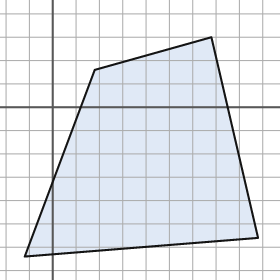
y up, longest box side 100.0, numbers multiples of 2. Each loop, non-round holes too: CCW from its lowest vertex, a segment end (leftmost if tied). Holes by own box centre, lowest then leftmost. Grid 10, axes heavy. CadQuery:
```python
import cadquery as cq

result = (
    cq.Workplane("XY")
    .moveTo(-12.0, -64.0)
    .lineTo(88.0, -56.0)
    .lineTo(68.0, 30.0)
    .lineTo(18.0, 16.0)
    .close()
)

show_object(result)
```